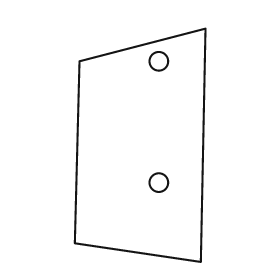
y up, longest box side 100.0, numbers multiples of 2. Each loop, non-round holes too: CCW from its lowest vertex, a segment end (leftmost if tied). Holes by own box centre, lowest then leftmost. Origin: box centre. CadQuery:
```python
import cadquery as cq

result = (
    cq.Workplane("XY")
    .moveTo(26.0, -50.0)
    .lineTo(28.0, 50.0)
    .lineTo(-26.0, 36.0)
    .lineTo(-28.0, -42.0)
    .close()
    .moveTo(8.0, -16.0)
    .circle(4.0)
    .moveTo(8.0, 36.0)
    .circle(4.0)
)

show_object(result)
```